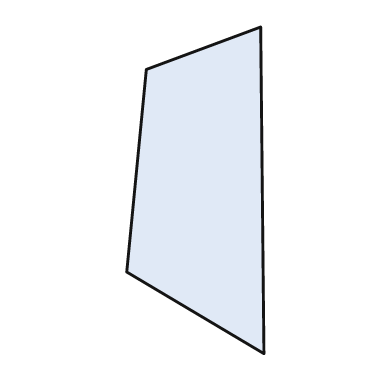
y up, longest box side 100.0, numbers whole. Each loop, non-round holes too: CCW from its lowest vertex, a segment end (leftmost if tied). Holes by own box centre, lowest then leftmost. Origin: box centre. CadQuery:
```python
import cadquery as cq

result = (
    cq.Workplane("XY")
    .moveTo(21.0, -50.0)
    .lineTo(20.0, 50.0)
    .lineTo(-15.0, 37.0)
    .lineTo(-21.0, -25.0)
    .close()
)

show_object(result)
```